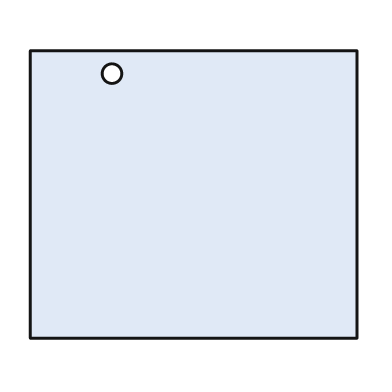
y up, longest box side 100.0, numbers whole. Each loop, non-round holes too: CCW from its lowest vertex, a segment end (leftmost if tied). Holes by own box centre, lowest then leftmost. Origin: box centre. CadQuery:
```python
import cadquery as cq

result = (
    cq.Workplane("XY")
    .moveTo(-50.0, -44.0)
    .lineTo(50.0, -44.0)
    .lineTo(50.0, 44.0)
    .lineTo(-50.0, 44.0)
    .close()
    .moveTo(-25.0, 37.0)
    .circle(3.0)
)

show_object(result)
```